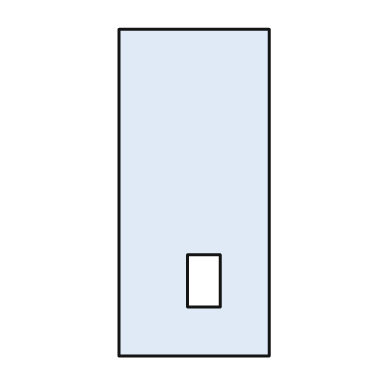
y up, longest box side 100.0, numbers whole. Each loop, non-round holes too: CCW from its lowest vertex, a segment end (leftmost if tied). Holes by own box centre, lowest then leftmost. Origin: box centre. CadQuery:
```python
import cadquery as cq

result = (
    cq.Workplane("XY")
    .moveTo(-23.0, -50.0)
    .lineTo(23.0, -50.0)
    .lineTo(23.0, 50.0)
    .lineTo(-23.0, 50.0)
    .close()
    .moveTo(-2.0, -35.0)
    .lineTo(8.0, -35.0)
    .lineTo(8.0, -19.0)
    .lineTo(-2.0, -19.0)
    .close()
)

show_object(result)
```